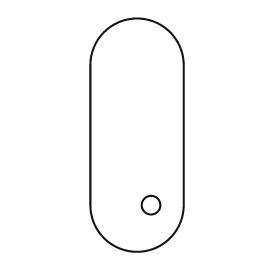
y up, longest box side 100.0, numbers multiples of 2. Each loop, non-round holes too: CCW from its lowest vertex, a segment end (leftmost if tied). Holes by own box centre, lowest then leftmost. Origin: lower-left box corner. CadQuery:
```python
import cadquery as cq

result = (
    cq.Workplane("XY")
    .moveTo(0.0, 20.0)
    .threePointArc((20.0, 0.0), (40.0, 20.0))
    .lineTo(40.0, 80.0)
    .threePointArc((20.0, 100.0), (0.0, 80.0))
    .close()
    .moveTo(26.0, 20.0)
    .circle(4.0)
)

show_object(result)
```